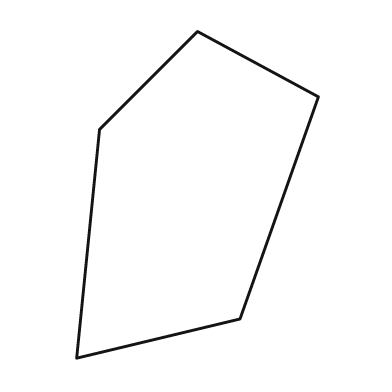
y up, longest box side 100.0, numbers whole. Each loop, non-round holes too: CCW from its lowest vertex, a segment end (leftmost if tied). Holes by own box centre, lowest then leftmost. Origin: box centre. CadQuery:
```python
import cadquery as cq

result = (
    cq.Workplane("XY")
    .moveTo(-37.0, -50.0)
    .lineTo(13.0, -38.0)
    .lineTo(37.0, 30.0)
    .lineTo(0.0, 50.0)
    .lineTo(-30.0, 20.0)
    .close()
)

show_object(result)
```